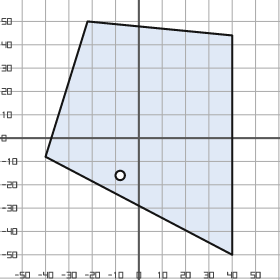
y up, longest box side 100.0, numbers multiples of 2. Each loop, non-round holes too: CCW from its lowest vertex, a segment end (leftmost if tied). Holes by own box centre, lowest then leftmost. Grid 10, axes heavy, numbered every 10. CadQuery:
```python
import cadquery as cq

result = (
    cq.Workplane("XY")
    .moveTo(40.0, -50.0)
    .lineTo(40.0, 44.0)
    .lineTo(-22.0, 50.0)
    .lineTo(-40.0, -8.0)
    .close()
    .moveTo(-8.0, -16.0)
    .circle(2.0)
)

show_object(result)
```